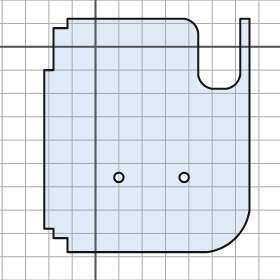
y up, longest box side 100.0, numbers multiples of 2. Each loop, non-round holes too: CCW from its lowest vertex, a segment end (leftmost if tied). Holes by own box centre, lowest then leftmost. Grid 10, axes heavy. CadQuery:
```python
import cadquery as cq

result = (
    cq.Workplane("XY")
    .moveTo(-12.0, -88.0)
    .lineTo(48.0, -88.0)
    .threePointArc((60.0, -82.0), (66.0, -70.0))
    .lineTo(66.0, 12.0)
    .lineTo(62.0, 12.0)
    .lineTo(62.0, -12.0)
    .threePointArc((60.0, -16.0), (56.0, -18.0))
    .lineTo(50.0, -18.0)
    .threePointArc((46.0, -16.0), (44.0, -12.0))
    .lineTo(44.0, 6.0)
    .threePointArc((42.0, 10.0), (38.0, 12.0))
    .lineTo(-12.0, 12.0)
    .lineTo(-12.0, 8.0)
    .lineTo(-18.0, 8.0)
    .lineTo(-18.0, -10.0)
    .lineTo(-22.0, -10.0)
    .lineTo(-22.0, -78.0)
    .lineTo(-18.0, -78.0)
    .lineTo(-18.0, -82.0)
    .lineTo(-12.0, -82.0)
    .close()
    .moveTo(10.0, -56.0)
    .circle(2.0)
    .moveTo(38.0, -56.0)
    .circle(2.0)
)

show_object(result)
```